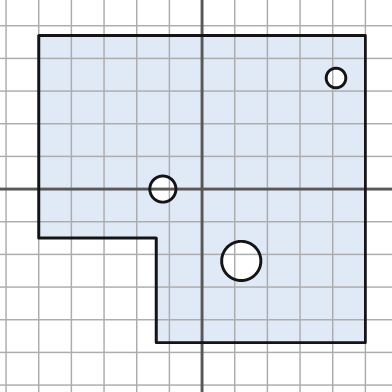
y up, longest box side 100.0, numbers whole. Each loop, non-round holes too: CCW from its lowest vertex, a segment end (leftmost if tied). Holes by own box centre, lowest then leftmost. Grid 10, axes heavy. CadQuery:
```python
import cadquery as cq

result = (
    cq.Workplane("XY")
    .moveTo(-14.0, -47.0)
    .lineTo(50.0, -47.0)
    .lineTo(50.0, 47.0)
    .lineTo(-50.0, 47.0)
    .lineTo(-50.0, -15.0)
    .lineTo(-14.0, -15.0)
    .close()
    .moveTo(12.0, -22.0)
    .circle(6.0)
    .moveTo(-12.0, 0.0)
    .circle(4.0)
    .moveTo(41.0, 34.0)
    .circle(3.0)
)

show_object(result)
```